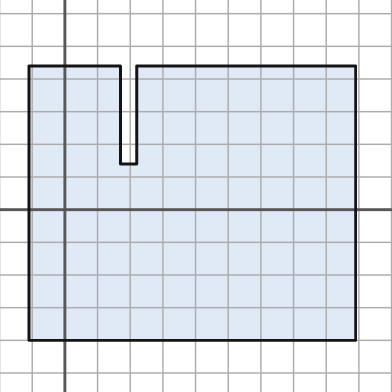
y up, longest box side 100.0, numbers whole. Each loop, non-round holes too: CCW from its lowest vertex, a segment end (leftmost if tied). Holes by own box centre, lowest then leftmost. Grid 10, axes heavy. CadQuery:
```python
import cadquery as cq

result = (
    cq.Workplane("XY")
    .moveTo(-11.0, -40.0)
    .lineTo(89.0, -40.0)
    .lineTo(89.0, 44.0)
    .lineTo(22.0, 44.0)
    .lineTo(22.0, 14.0)
    .lineTo(17.0, 14.0)
    .lineTo(17.0, 44.0)
    .lineTo(-11.0, 44.0)
    .close()
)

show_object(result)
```